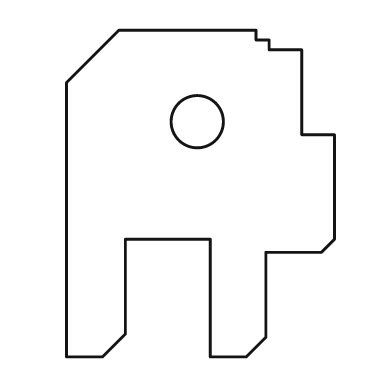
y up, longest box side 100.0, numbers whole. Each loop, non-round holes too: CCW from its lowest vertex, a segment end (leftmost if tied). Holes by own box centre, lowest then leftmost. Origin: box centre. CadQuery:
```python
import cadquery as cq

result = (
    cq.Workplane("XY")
    .moveTo(-41.0, -50.0)
    .lineTo(-30.0, -50.0)
    .lineTo(-23.0, -43.0)
    .lineTo(-23.0, -14.0)
    .lineTo(3.0, -14.0)
    .lineTo(3.0, -50.0)
    .lineTo(14.0, -50.0)
    .lineTo(20.0, -44.0)
    .lineTo(20.0, -18.0)
    .lineTo(37.0, -18.0)
    .lineTo(41.0, -14.0)
    .lineTo(41.0, 18.0)
    .lineTo(31.0, 18.0)
    .lineTo(31.0, 44.0)
    .lineTo(21.0, 44.0)
    .lineTo(21.0, 47.0)
    .lineTo(17.0, 47.0)
    .lineTo(17.0, 50.0)
    .lineTo(-25.0, 50.0)
    .lineTo(-41.0, 34.0)
    .close()
    .moveTo(-1.0, 22.0)
    .circle(8.0)
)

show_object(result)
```